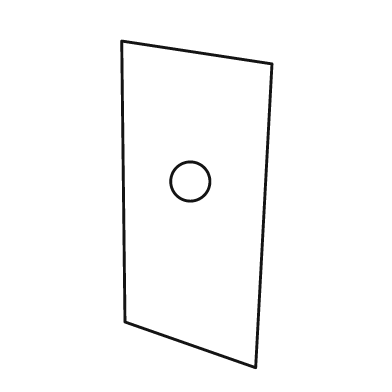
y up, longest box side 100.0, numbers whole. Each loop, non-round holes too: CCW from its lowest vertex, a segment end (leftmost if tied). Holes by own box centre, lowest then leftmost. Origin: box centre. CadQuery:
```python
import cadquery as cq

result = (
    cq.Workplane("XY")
    .moveTo(18.0, -50.0)
    .lineTo(23.0, 43.0)
    .lineTo(-23.0, 50.0)
    .lineTo(-22.0, -36.0)
    .close()
    .moveTo(-2.0, 7.0)
    .circle(6.0)
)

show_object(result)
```